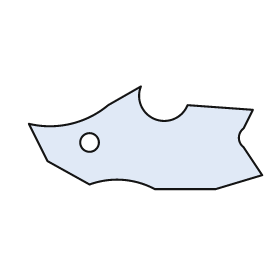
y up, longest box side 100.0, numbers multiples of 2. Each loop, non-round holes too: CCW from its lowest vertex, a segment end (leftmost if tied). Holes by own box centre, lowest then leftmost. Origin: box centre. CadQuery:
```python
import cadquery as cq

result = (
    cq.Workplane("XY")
    .moveTo(4.0, -22.0)
    .lineTo(30.0, -22.0)
    .lineTo(50.0, -16.0)
    .lineTo(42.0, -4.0)
    .threePointArc((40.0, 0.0), (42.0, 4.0))
    .lineTo(46.0, 12.0)
    .lineTo(18.0, 14.0)
    .threePointArc((4.0, 8.0), (-2.0, 22.0))
    .lineTo(-16.0, 14.0)
    .threePointArc((-32.0, 6.0), (-50.0, 6.0))
    .lineTo(-42.0, -10.0)
    .lineTo(-24.0, -20.0)
    .threePointArc((-10.0, -18.0), (4.0, -22.0))
    .close()
    .moveTo(-24.0, -2.0)
    .circle(4.0)
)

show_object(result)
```